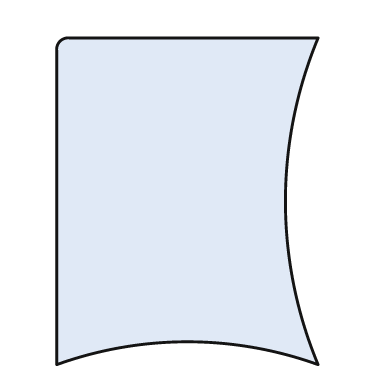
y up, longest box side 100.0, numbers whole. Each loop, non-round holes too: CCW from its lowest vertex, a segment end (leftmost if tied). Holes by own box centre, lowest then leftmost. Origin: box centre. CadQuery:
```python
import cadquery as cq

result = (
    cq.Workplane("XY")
    .moveTo(-40.0, -50.0)
    .threePointArc((0.0, -43.0), (40.0, -50.0))
    .threePointArc((30.0, 0.0), (40.0, 50.0))
    .lineTo(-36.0, 50.0)
    .threePointArc((-39.0, 49.0), (-40.0, 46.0))
    .close()
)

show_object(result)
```